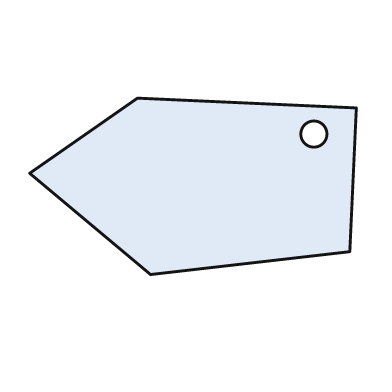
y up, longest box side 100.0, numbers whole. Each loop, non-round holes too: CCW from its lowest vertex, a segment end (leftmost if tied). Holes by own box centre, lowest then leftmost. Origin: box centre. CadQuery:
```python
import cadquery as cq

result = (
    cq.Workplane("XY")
    .moveTo(-13.0, -27.0)
    .lineTo(48.0, -20.0)
    .lineTo(50.0, 24.0)
    .lineTo(-17.0, 27.0)
    .lineTo(-50.0, 4.0)
    .close()
    .moveTo(37.0, 16.0)
    .circle(4.0)
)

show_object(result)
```